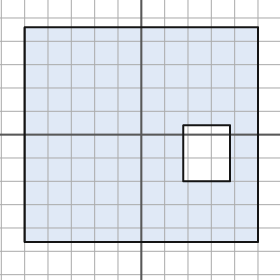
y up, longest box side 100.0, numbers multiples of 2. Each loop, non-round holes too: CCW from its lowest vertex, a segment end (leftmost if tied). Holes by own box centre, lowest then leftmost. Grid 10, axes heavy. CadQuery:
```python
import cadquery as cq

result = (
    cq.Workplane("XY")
    .moveTo(-50.0, -46.0)
    .lineTo(50.0, -46.0)
    .lineTo(50.0, 46.0)
    .lineTo(-50.0, 46.0)
    .close()
    .moveTo(18.0, -20.0)
    .lineTo(38.0, -20.0)
    .lineTo(38.0, 4.0)
    .lineTo(18.0, 4.0)
    .close()
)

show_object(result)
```